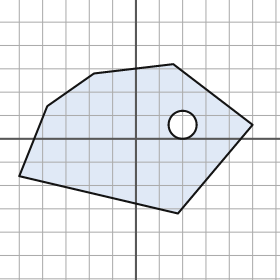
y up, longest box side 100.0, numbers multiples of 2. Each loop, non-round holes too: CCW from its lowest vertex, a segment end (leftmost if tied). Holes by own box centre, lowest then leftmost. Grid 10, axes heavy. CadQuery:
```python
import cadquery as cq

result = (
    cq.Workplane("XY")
    .moveTo(18.0, -32.0)
    .lineTo(50.0, 6.0)
    .lineTo(16.0, 32.0)
    .lineTo(-18.0, 28.0)
    .lineTo(-38.0, 14.0)
    .lineTo(-50.0, -16.0)
    .close()
    .moveTo(20.0, 6.0)
    .circle(6.0)
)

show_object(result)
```